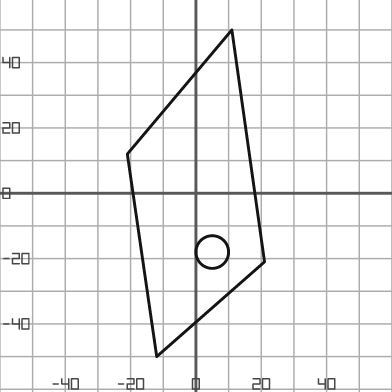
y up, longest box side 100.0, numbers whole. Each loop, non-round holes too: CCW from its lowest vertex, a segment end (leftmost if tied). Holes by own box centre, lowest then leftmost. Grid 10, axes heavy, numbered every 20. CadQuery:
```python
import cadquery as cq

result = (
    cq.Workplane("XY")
    .moveTo(-12.0, -50.0)
    .lineTo(21.0, -21.0)
    .lineTo(11.0, 50.0)
    .lineTo(-21.0, 12.0)
    .close()
    .moveTo(5.0, -18.0)
    .circle(5.0)
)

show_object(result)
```